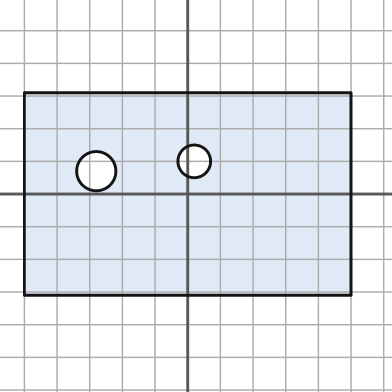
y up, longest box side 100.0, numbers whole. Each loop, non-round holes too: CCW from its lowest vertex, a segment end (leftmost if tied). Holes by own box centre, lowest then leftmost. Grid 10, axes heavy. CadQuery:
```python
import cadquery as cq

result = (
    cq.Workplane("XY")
    .moveTo(-50.0, -31.0)
    .lineTo(50.0, -31.0)
    .lineTo(50.0, 31.0)
    .lineTo(-50.0, 31.0)
    .close()
    .moveTo(-28.0, 7.0)
    .circle(6.0)
    .moveTo(2.0, 10.0)
    .circle(5.0)
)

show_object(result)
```